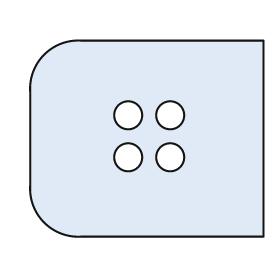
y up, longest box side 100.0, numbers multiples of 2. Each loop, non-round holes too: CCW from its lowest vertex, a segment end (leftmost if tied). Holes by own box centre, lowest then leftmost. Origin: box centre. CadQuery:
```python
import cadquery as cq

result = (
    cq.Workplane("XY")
    .moveTo(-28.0, -42.0)
    .lineTo(50.0, -42.0)
    .lineTo(50.0, 42.0)
    .lineTo(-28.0, 42.0)
    .threePointArc((-44.0, 36.0), (-50.0, 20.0))
    .lineTo(-50.0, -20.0)
    .threePointArc((-44.0, -36.0), (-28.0, -42.0))
    .close()
    .moveTo(-8.0, -8.0)
    .circle(6.0)
    .moveTo(10.0, -8.0)
    .circle(6.0)
    .moveTo(-8.0, 10.0)
    .circle(6.0)
    .moveTo(10.0, 10.0)
    .circle(6.0)
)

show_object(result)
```